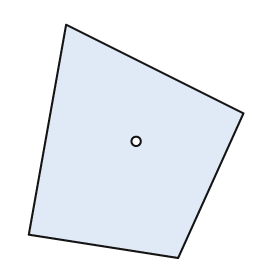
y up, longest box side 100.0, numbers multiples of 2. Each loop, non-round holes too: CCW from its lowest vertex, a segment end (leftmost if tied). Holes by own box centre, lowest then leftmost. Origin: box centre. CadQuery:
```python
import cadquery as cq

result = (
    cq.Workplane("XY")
    .moveTo(18.0, -50.0)
    .lineTo(46.0, 12.0)
    .lineTo(-30.0, 50.0)
    .lineTo(-46.0, -40.0)
    .close()
    .moveTo(0.0, 0.0)
    .circle(2.0)
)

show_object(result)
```